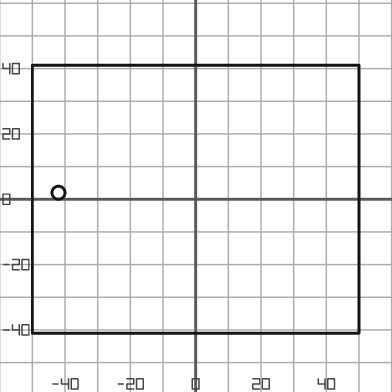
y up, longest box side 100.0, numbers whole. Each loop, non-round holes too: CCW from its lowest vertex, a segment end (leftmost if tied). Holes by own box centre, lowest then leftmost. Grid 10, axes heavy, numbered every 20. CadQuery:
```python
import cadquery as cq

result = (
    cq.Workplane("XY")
    .moveTo(-50.0, -41.0)
    .lineTo(50.0, -41.0)
    .lineTo(50.0, 41.0)
    .lineTo(-50.0, 41.0)
    .close()
    .moveTo(-42.0, 2.0)
    .circle(2.0)
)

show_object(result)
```